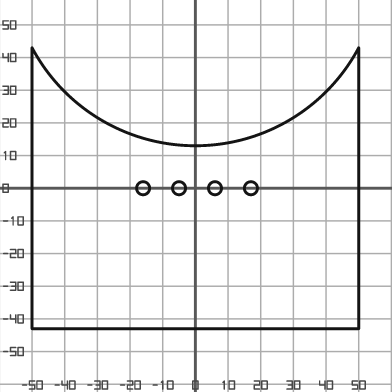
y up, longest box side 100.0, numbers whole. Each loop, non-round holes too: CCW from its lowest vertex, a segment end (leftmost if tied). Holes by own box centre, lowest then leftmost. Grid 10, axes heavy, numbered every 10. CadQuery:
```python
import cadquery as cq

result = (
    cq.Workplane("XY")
    .moveTo(-50.0, -43.0)
    .lineTo(50.0, -43.0)
    .lineTo(50.0, 43.0)
    .threePointArc((0.0, 13.0), (-50.0, 43.0))
    .close()
    .moveTo(-16.0, 0.0)
    .circle(2.0)
    .moveTo(-5.0, 0.0)
    .circle(2.0)
    .moveTo(6.0, 0.0)
    .circle(2.0)
    .moveTo(17.0, 0.0)
    .circle(2.0)
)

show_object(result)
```